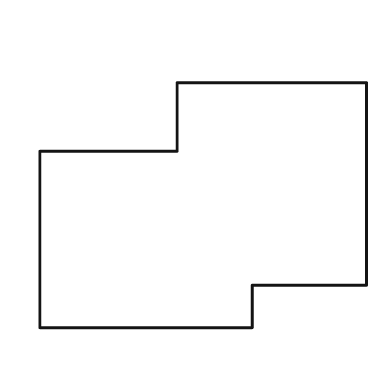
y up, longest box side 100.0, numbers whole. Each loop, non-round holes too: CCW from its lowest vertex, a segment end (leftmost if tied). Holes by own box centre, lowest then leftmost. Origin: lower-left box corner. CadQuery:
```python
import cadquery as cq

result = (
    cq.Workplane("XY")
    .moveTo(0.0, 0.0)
    .lineTo(65.0, 0.0)
    .lineTo(65.0, 13.0)
    .lineTo(100.0, 13.0)
    .lineTo(100.0, 75.0)
    .lineTo(42.0, 75.0)
    .lineTo(42.0, 54.0)
    .lineTo(0.0, 54.0)
    .close()
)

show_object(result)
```